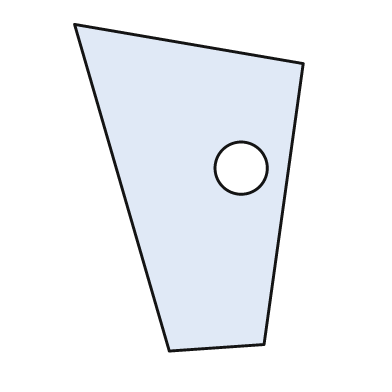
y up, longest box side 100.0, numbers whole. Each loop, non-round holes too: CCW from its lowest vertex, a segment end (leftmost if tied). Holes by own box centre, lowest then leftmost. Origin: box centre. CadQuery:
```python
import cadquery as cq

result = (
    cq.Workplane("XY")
    .moveTo(-6.0, -50.0)
    .lineTo(23.0, -48.0)
    .lineTo(35.0, 38.0)
    .lineTo(-35.0, 50.0)
    .close()
    .moveTo(16.0, 6.0)
    .circle(8.0)
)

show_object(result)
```